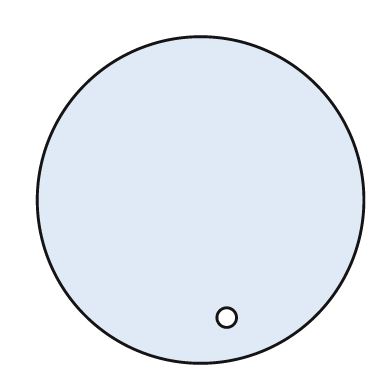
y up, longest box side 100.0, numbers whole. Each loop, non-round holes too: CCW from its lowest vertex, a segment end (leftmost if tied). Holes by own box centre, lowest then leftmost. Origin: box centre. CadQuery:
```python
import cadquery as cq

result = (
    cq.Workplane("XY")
    .moveTo(0.0, 0.0)
    .circle(50.0)
    .moveTo(8.0, -36.0)
    .circle(3.0)
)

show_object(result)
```